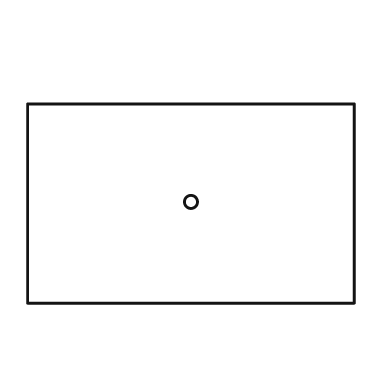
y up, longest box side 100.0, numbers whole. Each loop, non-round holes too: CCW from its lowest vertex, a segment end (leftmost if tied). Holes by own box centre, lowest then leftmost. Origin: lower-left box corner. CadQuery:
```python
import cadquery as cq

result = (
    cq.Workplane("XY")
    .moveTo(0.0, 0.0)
    .lineTo(100.0, 0.0)
    .lineTo(100.0, 61.0)
    .lineTo(0.0, 61.0)
    .close()
    .moveTo(50.0, 31.0)
    .circle(2.0)
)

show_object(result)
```